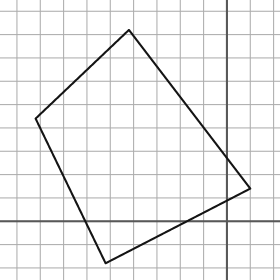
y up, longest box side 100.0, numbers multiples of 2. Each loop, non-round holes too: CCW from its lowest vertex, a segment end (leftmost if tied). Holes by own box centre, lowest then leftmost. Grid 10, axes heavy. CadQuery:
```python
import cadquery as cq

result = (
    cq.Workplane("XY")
    .moveTo(-52.0, -18.0)
    .lineTo(10.0, 14.0)
    .lineTo(-42.0, 82.0)
    .lineTo(-82.0, 44.0)
    .close()
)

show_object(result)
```